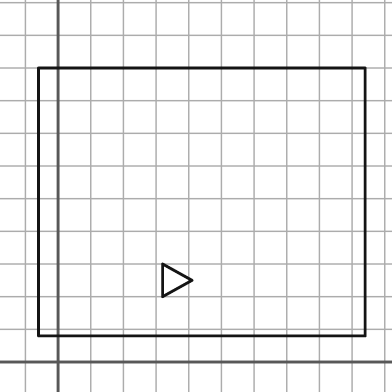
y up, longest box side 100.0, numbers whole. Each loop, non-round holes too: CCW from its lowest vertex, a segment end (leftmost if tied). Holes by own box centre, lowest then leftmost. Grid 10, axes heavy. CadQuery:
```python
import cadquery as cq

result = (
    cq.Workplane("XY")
    .moveTo(-6.0, 8.0)
    .lineTo(94.0, 8.0)
    .lineTo(94.0, 90.0)
    .lineTo(-6.0, 90.0)
    .close()
    .moveTo(32.0, 20.0)
    .lineTo(41.0, 25.0)
    .lineTo(32.0, 30.0)
    .close()
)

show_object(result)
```